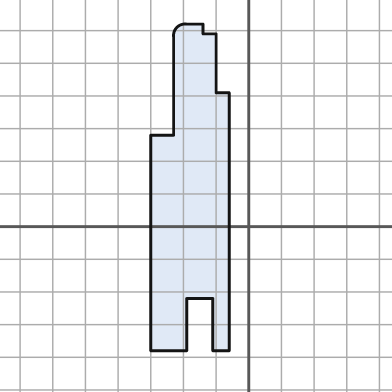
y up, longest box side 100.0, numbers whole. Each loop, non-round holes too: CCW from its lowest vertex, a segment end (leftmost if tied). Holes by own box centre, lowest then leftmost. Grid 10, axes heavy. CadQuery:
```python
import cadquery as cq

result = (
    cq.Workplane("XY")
    .moveTo(-30.0, -38.0)
    .lineTo(-19.0, -38.0)
    .lineTo(-19.0, -22.0)
    .lineTo(-11.0, -22.0)
    .lineTo(-11.0, -38.0)
    .lineTo(-6.0, -38.0)
    .lineTo(-6.0, 41.0)
    .lineTo(-10.0, 41.0)
    .lineTo(-10.0, 59.0)
    .lineTo(-14.0, 59.0)
    .lineTo(-14.0, 62.0)
    .lineTo(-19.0, 62.0)
    .threePointArc((-22.0, 61.0), (-23.0, 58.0))
    .lineTo(-23.0, 28.0)
    .lineTo(-30.0, 28.0)
    .close()
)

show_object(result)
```